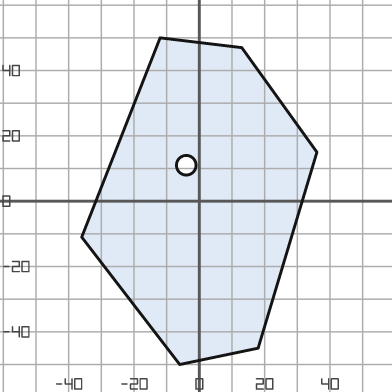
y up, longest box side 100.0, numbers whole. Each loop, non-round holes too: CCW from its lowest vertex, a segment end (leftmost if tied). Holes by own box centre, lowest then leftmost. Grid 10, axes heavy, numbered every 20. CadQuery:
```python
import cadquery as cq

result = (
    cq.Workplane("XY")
    .moveTo(-6.0, -50.0)
    .lineTo(18.0, -45.0)
    .lineTo(36.0, 15.0)
    .lineTo(13.0, 47.0)
    .lineTo(-12.0, 50.0)
    .lineTo(-36.0, -11.0)
    .close()
    .moveTo(-4.0, 11.0)
    .circle(3.0)
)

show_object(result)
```